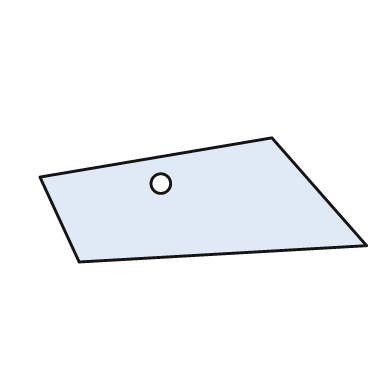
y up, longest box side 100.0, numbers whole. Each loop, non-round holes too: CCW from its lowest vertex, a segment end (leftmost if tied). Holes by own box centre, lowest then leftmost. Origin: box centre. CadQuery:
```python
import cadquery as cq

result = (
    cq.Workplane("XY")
    .moveTo(-38.0, -19.0)
    .lineTo(50.0, -14.0)
    .lineTo(21.0, 19.0)
    .lineTo(-50.0, 7.0)
    .close()
    .moveTo(-13.0, 5.0)
    .circle(3.0)
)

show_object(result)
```